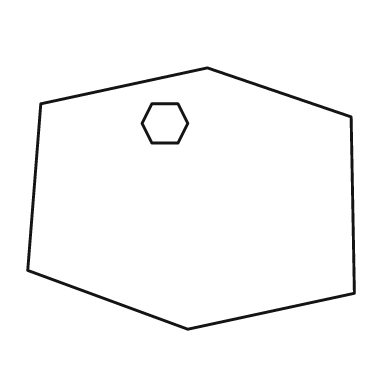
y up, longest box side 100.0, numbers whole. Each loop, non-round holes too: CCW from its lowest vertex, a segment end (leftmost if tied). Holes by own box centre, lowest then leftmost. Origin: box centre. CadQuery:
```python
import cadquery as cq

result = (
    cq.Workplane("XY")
    .moveTo(-1.0, -40.0)
    .lineTo(50.0, -29.0)
    .lineTo(49.0, 25.0)
    .lineTo(5.0, 40.0)
    .lineTo(-46.0, 29.0)
    .lineTo(-50.0, -22.0)
    .close()
    .moveTo(-12.0, 17.0)
    .lineTo(-4.0, 17.0)
    .lineTo(-1.0, 23.0)
    .lineTo(-4.0, 29.0)
    .lineTo(-12.0, 29.0)
    .lineTo(-15.0, 23.0)
    .close()
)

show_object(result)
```